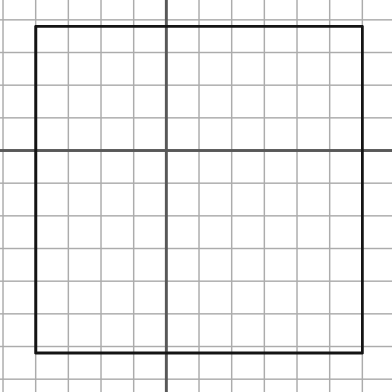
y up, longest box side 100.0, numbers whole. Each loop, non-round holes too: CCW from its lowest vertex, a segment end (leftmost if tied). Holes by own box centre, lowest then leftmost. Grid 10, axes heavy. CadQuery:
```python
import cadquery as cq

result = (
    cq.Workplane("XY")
    .moveTo(-40.0, -62.0)
    .lineTo(60.0, -62.0)
    .lineTo(60.0, 38.0)
    .lineTo(-40.0, 38.0)
    .close()
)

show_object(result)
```